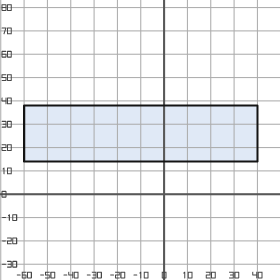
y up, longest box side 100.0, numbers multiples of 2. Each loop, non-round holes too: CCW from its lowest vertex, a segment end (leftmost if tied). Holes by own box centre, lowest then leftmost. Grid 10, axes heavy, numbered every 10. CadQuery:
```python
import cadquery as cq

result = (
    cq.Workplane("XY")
    .moveTo(-60.0, 14.0)
    .lineTo(40.0, 14.0)
    .lineTo(40.0, 38.0)
    .lineTo(-60.0, 38.0)
    .close()
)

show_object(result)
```